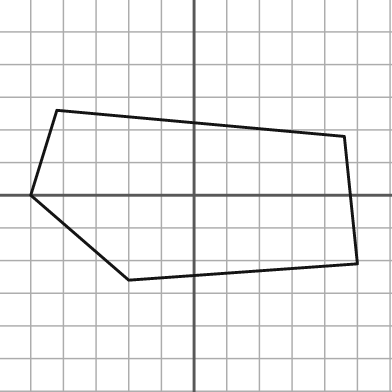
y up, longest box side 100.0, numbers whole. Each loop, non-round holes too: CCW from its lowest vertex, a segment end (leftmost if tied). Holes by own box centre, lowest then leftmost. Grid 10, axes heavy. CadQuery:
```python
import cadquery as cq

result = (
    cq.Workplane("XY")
    .moveTo(-20.0, -26.0)
    .lineTo(50.0, -21.0)
    .lineTo(46.0, 18.0)
    .lineTo(-42.0, 26.0)
    .lineTo(-50.0, 0.0)
    .close()
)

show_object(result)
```